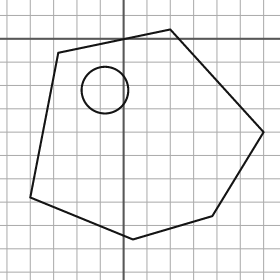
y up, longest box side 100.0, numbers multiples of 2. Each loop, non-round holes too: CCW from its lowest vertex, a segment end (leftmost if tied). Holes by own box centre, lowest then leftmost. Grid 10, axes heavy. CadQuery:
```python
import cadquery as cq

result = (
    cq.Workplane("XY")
    .moveTo(4.0, -86.0)
    .lineTo(38.0, -76.0)
    .lineTo(60.0, -40.0)
    .lineTo(20.0, 4.0)
    .lineTo(-28.0, -6.0)
    .lineTo(-40.0, -68.0)
    .close()
    .moveTo(-8.0, -22.0)
    .circle(10.0)
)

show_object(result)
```